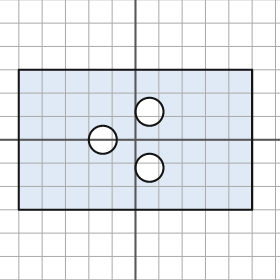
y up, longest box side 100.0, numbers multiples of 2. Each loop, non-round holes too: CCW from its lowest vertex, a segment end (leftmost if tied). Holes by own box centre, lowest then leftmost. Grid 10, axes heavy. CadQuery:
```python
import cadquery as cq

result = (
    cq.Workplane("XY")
    .moveTo(-50.0, -30.0)
    .lineTo(50.0, -30.0)
    .lineTo(50.0, 30.0)
    .lineTo(-50.0, 30.0)
    .close()
    .moveTo(6.0, -12.0)
    .circle(6.0)
    .moveTo(-14.0, 0.0)
    .circle(6.0)
    .moveTo(6.0, 12.0)
    .circle(6.0)
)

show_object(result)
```